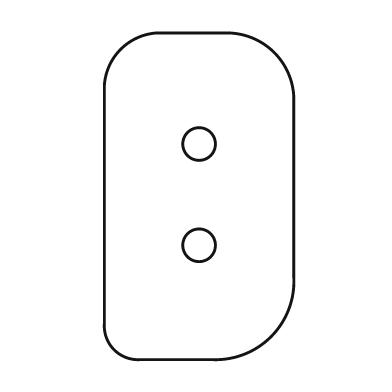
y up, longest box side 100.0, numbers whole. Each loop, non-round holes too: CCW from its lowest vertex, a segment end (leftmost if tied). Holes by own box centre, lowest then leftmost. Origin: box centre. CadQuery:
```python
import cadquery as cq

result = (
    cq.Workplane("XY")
    .moveTo(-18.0, -50.0)
    .lineTo(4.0, -50.0)
    .threePointArc((22.0, -43.0), (29.0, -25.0))
    .lineTo(29.0, 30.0)
    .threePointArc((23.0, 44.0), (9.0, 50.0))
    .lineTo(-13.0, 50.0)
    .threePointArc((-24.0, 45.0), (-29.0, 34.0))
    .lineTo(-29.0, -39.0)
    .threePointArc((-26.0, -47.0), (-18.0, -50.0))
    .close()
    .moveTo(0.0, -15.0)
    .circle(5.0)
    .moveTo(0.0, 16.0)
    .circle(5.0)
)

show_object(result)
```